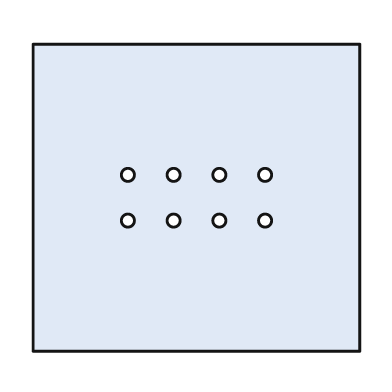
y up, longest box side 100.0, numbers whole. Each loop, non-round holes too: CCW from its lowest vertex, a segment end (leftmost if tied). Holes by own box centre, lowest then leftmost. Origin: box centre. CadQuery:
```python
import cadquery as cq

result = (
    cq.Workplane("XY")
    .moveTo(-50.0, -47.0)
    .lineTo(50.0, -47.0)
    .lineTo(50.0, 47.0)
    .lineTo(-50.0, 47.0)
    .close()
    .moveTo(-21.0, -7.0)
    .circle(2.0)
    .moveTo(-7.0, -7.0)
    .circle(2.0)
    .moveTo(7.0, -7.0)
    .circle(2.0)
    .moveTo(21.0, -7.0)
    .circle(2.0)
    .moveTo(-21.0, 7.0)
    .circle(2.0)
    .moveTo(-7.0, 7.0)
    .circle(2.0)
    .moveTo(7.0, 7.0)
    .circle(2.0)
    .moveTo(21.0, 7.0)
    .circle(2.0)
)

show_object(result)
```